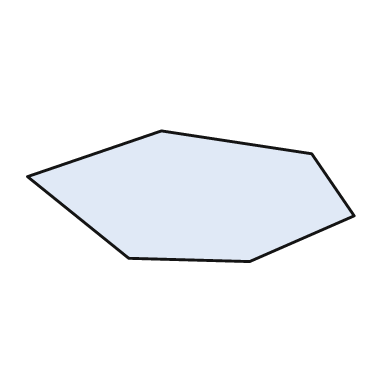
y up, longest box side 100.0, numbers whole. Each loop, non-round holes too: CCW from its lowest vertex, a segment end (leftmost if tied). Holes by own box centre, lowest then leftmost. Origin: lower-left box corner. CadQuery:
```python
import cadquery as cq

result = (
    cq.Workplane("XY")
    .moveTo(68.0, 0.0)
    .lineTo(100.0, 14.0)
    .lineTo(87.0, 33.0)
    .lineTo(41.0, 40.0)
    .lineTo(0.0, 26.0)
    .lineTo(31.0, 1.0)
    .close()
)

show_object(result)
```